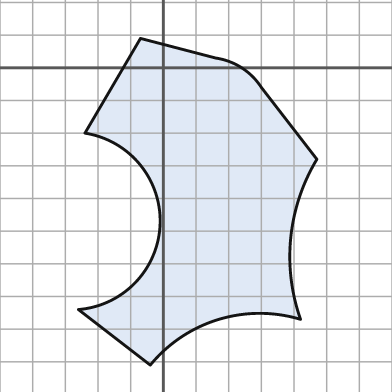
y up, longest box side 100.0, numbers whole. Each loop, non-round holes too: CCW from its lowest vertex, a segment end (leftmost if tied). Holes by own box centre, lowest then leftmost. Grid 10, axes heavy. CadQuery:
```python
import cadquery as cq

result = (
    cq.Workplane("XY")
    .moveTo(-4.0, -91.0)
    .threePointArc((17.0, -77.0), (42.0, -77.0))
    .threePointArc((39.0, -52.0), (47.0, -28.0))
    .lineTo(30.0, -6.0)
    .threePointArc((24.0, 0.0), (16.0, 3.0))
    .lineTo(-7.0, 9.0)
    .lineTo(-24.0, -20.0)
    .threePointArc((-1.0, -48.0), (-26.0, -74.0))
    .close()
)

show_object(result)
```